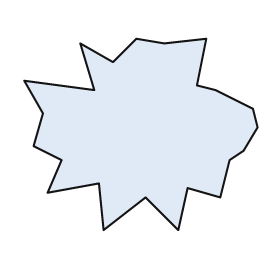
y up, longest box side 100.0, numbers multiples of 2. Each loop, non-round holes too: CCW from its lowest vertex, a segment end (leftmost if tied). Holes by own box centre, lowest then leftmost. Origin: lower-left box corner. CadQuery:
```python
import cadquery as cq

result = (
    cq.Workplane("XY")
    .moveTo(34.0, 0.0)
    .lineTo(52.0, 14.0)
    .lineTo(66.0, 0.0)
    .lineTo(70.0, 18.0)
    .lineTo(84.0, 14.0)
    .lineTo(88.0, 30.0)
    .lineTo(94.0, 34.0)
    .lineTo(100.0, 44.0)
    .lineTo(98.0, 52.0)
    .lineTo(82.0, 60.0)
    .lineTo(74.0, 62.0)
    .lineTo(78.0, 82.0)
    .lineTo(60.0, 80.0)
    .lineTo(48.0, 82.0)
    .lineTo(38.0, 72.0)
    .lineTo(24.0, 80.0)
    .lineTo(30.0, 60.0)
    .lineTo(0.0, 64.0)
    .lineTo(8.0, 50.0)
    .lineTo(4.0, 36.0)
    .lineTo(16.0, 30.0)
    .lineTo(10.0, 16.0)
    .lineTo(32.0, 20.0)
    .close()
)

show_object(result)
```